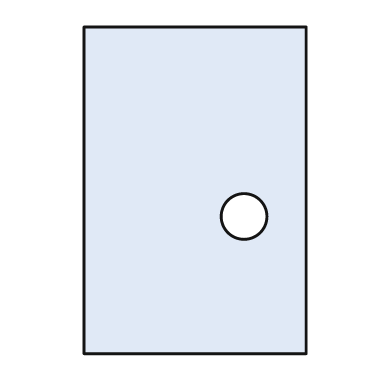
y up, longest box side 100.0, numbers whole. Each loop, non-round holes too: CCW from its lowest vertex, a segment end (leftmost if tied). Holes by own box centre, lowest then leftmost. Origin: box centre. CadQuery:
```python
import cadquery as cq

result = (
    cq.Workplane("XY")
    .moveTo(-34.0, -50.0)
    .lineTo(34.0, -50.0)
    .lineTo(34.0, 50.0)
    .lineTo(-34.0, 50.0)
    .close()
    .moveTo(15.0, -8.0)
    .circle(7.0)
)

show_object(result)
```